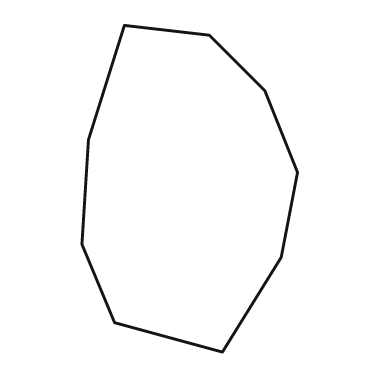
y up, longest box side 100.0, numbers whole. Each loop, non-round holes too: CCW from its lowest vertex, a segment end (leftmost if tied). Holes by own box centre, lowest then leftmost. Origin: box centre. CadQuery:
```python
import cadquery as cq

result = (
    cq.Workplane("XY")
    .moveTo(10.0, -50.0)
    .lineTo(28.0, -21.0)
    .lineTo(33.0, 5.0)
    .lineTo(23.0, 30.0)
    .lineTo(6.0, 47.0)
    .lineTo(-20.0, 50.0)
    .lineTo(-31.0, 15.0)
    .lineTo(-33.0, -17.0)
    .lineTo(-23.0, -41.0)
    .close()
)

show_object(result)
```